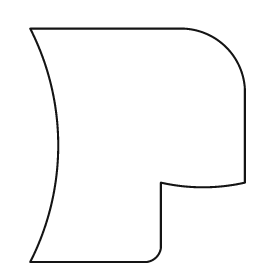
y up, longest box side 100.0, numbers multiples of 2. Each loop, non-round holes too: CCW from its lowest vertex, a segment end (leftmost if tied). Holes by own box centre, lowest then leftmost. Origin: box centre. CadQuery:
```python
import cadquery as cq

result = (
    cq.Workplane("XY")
    .moveTo(-46.0, -50.0)
    .lineTo(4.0, -50.0)
    .threePointArc((8.0, -48.0), (10.0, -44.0))
    .lineTo(10.0, -16.0)
    .threePointArc((28.0, -18.0), (46.0, -16.0))
    .lineTo(46.0, 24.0)
    .threePointArc((38.0, 42.0), (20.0, 50.0))
    .lineTo(-46.0, 50.0)
    .threePointArc((-34.0, 0.0), (-46.0, -50.0))
    .close()
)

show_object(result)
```